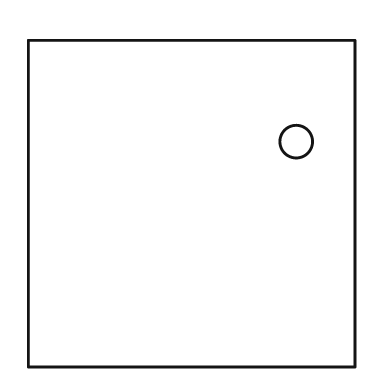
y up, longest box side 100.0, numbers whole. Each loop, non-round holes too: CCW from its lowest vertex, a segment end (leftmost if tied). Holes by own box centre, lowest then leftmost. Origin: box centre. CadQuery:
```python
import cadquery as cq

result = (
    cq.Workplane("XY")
    .moveTo(-50.0, -50.0)
    .lineTo(50.0, -50.0)
    .lineTo(50.0, 50.0)
    .lineTo(-50.0, 50.0)
    .close()
    .moveTo(32.0, 19.0)
    .circle(5.0)
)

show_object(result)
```